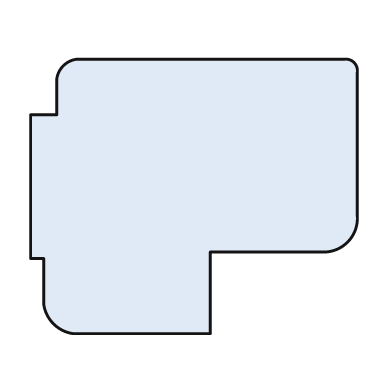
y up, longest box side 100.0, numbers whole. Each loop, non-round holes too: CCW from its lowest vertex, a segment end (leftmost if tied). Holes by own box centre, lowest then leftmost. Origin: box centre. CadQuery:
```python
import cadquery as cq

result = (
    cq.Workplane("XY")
    .moveTo(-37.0, -42.0)
    .lineTo(5.0, -42.0)
    .lineTo(5.0, -17.0)
    .lineTo(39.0, -17.0)
    .threePointArc((47.0, -14.0), (50.0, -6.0))
    .lineTo(50.0, 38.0)
    .threePointArc((49.0, 41.0), (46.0, 42.0))
    .lineTo(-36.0, 42.0)
    .threePointArc((-40.0, 40.0), (-42.0, 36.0))
    .lineTo(-42.0, 25.0)
    .lineTo(-50.0, 25.0)
    .lineTo(-50.0, -19.0)
    .lineTo(-46.0, -19.0)
    .lineTo(-46.0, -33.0)
    .threePointArc((-43.0, -39.0), (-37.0, -42.0))
    .close()
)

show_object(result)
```